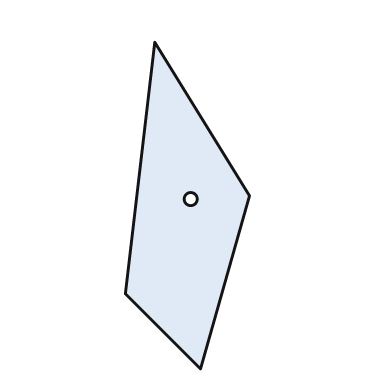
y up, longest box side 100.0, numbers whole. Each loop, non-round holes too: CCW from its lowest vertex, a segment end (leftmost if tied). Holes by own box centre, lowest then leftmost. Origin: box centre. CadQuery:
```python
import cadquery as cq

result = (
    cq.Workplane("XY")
    .moveTo(4.0, -50.0)
    .lineTo(19.0, 3.0)
    .lineTo(-10.0, 50.0)
    .lineTo(-19.0, -27.0)
    .close()
    .moveTo(1.0, 2.0)
    .circle(2.0)
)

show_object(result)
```